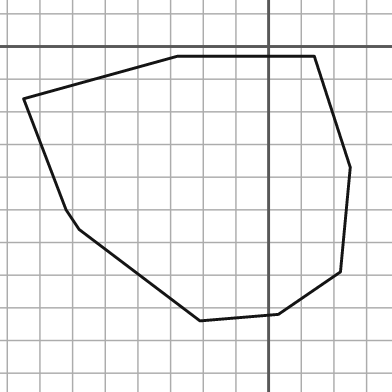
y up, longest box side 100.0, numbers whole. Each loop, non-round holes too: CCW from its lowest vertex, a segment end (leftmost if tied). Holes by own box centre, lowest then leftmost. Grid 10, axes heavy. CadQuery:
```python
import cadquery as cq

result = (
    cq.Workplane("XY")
    .moveTo(-21.0, -84.0)
    .lineTo(3.0, -82.0)
    .lineTo(22.0, -69.0)
    .lineTo(25.0, -37.0)
    .lineTo(14.0, -3.0)
    .lineTo(-28.0, -3.0)
    .lineTo(-75.0, -16.0)
    .lineTo(-62.0, -50.0)
    .lineTo(-58.0, -56.0)
    .close()
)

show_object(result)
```